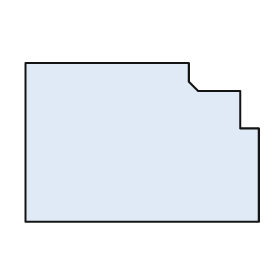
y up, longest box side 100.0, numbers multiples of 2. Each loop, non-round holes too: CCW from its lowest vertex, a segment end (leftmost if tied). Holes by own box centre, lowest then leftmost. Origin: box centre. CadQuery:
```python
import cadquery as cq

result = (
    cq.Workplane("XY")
    .moveTo(-50.0, -34.0)
    .lineTo(50.0, -34.0)
    .lineTo(50.0, 6.0)
    .lineTo(42.0, 6.0)
    .lineTo(42.0, 22.0)
    .lineTo(24.0, 22.0)
    .lineTo(20.0, 26.0)
    .lineTo(20.0, 34.0)
    .lineTo(-50.0, 34.0)
    .close()
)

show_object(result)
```